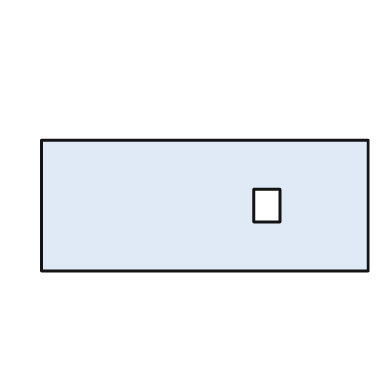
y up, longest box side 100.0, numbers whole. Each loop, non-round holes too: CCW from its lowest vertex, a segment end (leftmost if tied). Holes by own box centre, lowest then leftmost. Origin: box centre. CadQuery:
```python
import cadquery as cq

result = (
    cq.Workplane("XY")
    .moveTo(-50.0, -20.0)
    .lineTo(50.0, -20.0)
    .lineTo(50.0, 20.0)
    .lineTo(-50.0, 20.0)
    .close()
    .moveTo(15.0, -5.0)
    .lineTo(23.0, -5.0)
    .lineTo(23.0, 5.0)
    .lineTo(15.0, 5.0)
    .close()
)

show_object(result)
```